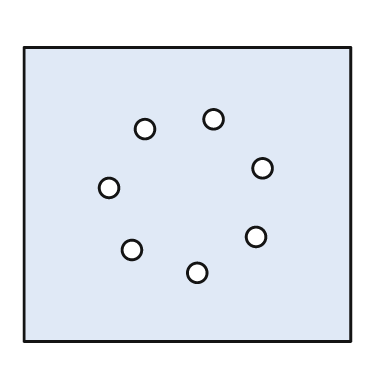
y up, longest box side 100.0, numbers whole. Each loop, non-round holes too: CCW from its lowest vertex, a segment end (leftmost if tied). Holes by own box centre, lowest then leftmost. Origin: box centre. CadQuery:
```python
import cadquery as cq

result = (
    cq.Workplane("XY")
    .moveTo(-50.0, -45.0)
    .lineTo(50.0, -45.0)
    .lineTo(50.0, 45.0)
    .lineTo(-50.0, 45.0)
    .close()
    .moveTo(3.0, -24.0)
    .circle(3.0)
    .moveTo(-17.0, -17.0)
    .circle(3.0)
    .moveTo(21.0, -13.0)
    .circle(3.0)
    .moveTo(-24.0, 2.0)
    .circle(3.0)
    .moveTo(23.0, 8.0)
    .circle(3.0)
    .moveTo(-13.0, 20.0)
    .circle(3.0)
    .moveTo(8.0, 23.0)
    .circle(3.0)
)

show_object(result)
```